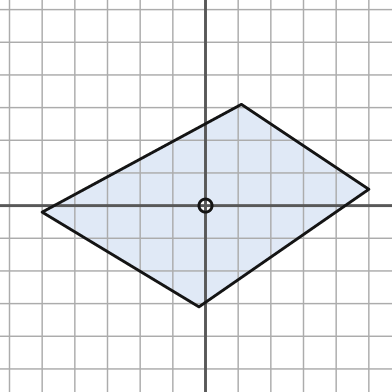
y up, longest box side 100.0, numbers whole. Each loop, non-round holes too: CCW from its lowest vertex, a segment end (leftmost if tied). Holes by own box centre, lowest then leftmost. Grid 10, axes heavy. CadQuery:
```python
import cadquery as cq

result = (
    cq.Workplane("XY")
    .moveTo(-2.0, -31.0)
    .lineTo(50.0, 5.0)
    .lineTo(11.0, 31.0)
    .lineTo(-50.0, -2.0)
    .close()
    .moveTo(0.0, 0.0)
    .circle(2.0)
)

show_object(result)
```